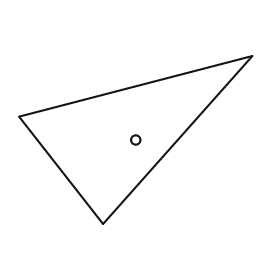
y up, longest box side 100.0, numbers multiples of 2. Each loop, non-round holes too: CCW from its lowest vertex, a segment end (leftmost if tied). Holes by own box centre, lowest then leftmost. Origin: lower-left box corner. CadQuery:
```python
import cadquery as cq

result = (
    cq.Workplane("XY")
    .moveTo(36.0, 0.0)
    .lineTo(100.0, 72.0)
    .lineTo(0.0, 46.0)
    .close()
    .moveTo(50.0, 36.0)
    .circle(2.0)
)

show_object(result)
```